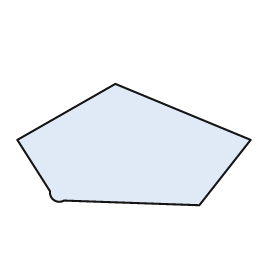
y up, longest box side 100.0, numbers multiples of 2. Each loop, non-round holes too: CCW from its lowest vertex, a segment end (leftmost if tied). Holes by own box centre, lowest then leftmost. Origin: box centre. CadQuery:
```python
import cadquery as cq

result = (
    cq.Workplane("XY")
    .moveTo(28.0, -26.0)
    .lineTo(50.0, 2.0)
    .lineTo(-8.0, 26.0)
    .lineTo(-50.0, 2.0)
    .lineTo(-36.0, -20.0)
    .threePointArc((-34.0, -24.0), (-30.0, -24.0))
    .close()
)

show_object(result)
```